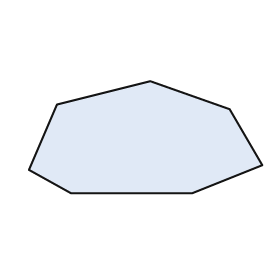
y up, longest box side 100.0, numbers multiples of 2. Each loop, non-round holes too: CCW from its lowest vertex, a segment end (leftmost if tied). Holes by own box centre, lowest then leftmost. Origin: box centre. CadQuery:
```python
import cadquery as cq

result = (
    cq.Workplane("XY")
    .moveTo(-32.0, -24.0)
    .lineTo(20.0, -24.0)
    .lineTo(50.0, -12.0)
    .lineTo(36.0, 12.0)
    .lineTo(2.0, 24.0)
    .lineTo(-38.0, 14.0)
    .lineTo(-50.0, -14.0)
    .close()
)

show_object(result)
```